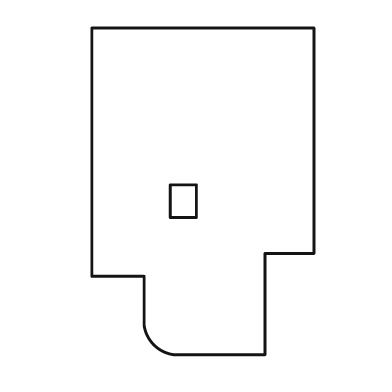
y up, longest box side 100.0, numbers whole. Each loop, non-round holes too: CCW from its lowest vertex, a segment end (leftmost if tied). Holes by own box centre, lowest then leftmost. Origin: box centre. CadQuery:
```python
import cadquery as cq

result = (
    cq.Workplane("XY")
    .moveTo(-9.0, -50.0)
    .lineTo(19.0, -50.0)
    .lineTo(19.0, -19.0)
    .lineTo(34.0, -19.0)
    .lineTo(34.0, 50.0)
    .lineTo(-34.0, 50.0)
    .lineTo(-34.0, -26.0)
    .lineTo(-18.0, -26.0)
    .lineTo(-18.0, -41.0)
    .threePointArc((-15.0, -47.0), (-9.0, -50.0))
    .close()
    .moveTo(-10.0, -8.0)
    .lineTo(-2.0, -8.0)
    .lineTo(-2.0, 2.0)
    .lineTo(-10.0, 2.0)
    .close()
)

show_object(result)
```